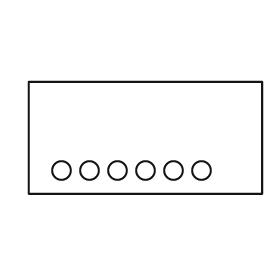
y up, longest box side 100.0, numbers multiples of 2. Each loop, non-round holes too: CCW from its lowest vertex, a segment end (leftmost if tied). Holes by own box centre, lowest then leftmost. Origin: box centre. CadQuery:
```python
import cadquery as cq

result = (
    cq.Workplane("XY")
    .moveTo(-50.0, -24.0)
    .lineTo(50.0, -24.0)
    .lineTo(50.0, 24.0)
    .lineTo(-50.0, 24.0)
    .close()
    .moveTo(-36.0, -14.0)
    .circle(4.0)
    .moveTo(-24.0, -14.0)
    .circle(4.0)
    .moveTo(-12.0, -14.0)
    .circle(4.0)
    .moveTo(0.0, -14.0)
    .circle(4.0)
    .moveTo(12.0, -14.0)
    .circle(4.0)
    .moveTo(24.0, -14.0)
    .circle(4.0)
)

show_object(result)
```